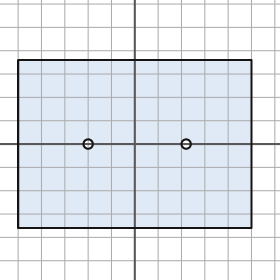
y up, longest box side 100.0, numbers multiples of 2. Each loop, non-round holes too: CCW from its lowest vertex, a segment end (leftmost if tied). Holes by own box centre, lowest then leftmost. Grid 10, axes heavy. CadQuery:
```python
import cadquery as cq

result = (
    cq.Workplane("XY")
    .moveTo(-50.0, -36.0)
    .lineTo(50.0, -36.0)
    .lineTo(50.0, 36.0)
    .lineTo(-50.0, 36.0)
    .close()
    .moveTo(-20.0, 0.0)
    .circle(2.0)
    .moveTo(22.0, 0.0)
    .circle(2.0)
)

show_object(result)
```